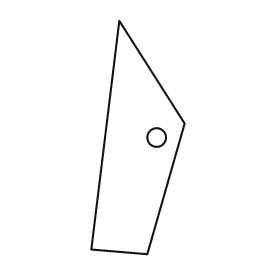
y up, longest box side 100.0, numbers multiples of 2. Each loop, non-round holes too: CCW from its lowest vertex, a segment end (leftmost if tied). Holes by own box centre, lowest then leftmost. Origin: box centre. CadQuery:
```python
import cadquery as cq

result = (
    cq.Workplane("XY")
    .moveTo(4.0, -50.0)
    .lineTo(20.0, 6.0)
    .lineTo(-8.0, 50.0)
    .lineTo(-20.0, -48.0)
    .close()
    .moveTo(8.0, 0.0)
    .circle(4.0)
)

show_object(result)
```